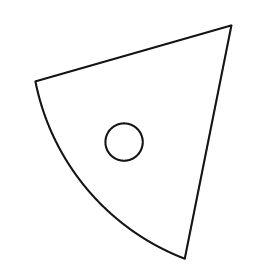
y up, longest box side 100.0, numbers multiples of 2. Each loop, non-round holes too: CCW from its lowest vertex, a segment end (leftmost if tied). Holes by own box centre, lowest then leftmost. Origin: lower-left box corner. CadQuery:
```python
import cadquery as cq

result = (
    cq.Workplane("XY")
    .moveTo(64.0, 0.0)
    .lineTo(84.0, 100.0)
    .lineTo(0.0, 76.0)
    .threePointArc((22.0, 30.0), (64.0, 0.0))
    .close()
    .moveTo(38.0, 50.0)
    .circle(8.0)
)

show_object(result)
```